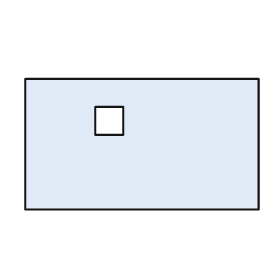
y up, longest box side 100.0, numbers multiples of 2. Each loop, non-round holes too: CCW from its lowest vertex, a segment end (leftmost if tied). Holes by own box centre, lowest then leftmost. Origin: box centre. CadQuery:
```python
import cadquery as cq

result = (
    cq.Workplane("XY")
    .moveTo(-50.0, -28.0)
    .lineTo(50.0, -28.0)
    .lineTo(50.0, 28.0)
    .lineTo(-50.0, 28.0)
    .close()
    .moveTo(-20.0, 4.0)
    .lineTo(-8.0, 4.0)
    .lineTo(-8.0, 16.0)
    .lineTo(-20.0, 16.0)
    .close()
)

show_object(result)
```